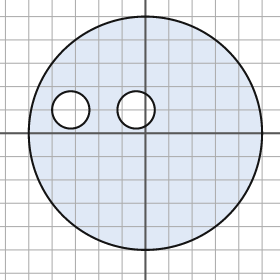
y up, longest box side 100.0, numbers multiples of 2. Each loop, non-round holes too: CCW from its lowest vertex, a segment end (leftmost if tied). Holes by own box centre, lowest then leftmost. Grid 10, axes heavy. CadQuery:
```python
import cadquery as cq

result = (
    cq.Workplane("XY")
    .moveTo(0.0, 0.0)
    .circle(50.0)
    .moveTo(-32.0, 10.0)
    .circle(8.0)
    .moveTo(-4.0, 10.0)
    .circle(8.0)
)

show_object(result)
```